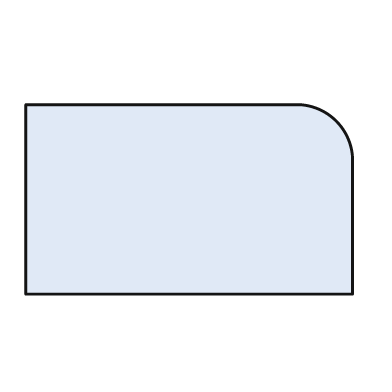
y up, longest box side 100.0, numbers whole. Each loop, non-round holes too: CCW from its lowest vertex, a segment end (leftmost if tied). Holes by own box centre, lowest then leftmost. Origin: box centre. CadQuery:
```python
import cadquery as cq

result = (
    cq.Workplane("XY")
    .moveTo(-50.0, -29.0)
    .lineTo(50.0, -29.0)
    .lineTo(50.0, 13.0)
    .threePointArc((45.0, 24.0), (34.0, 29.0))
    .lineTo(-50.0, 29.0)
    .close()
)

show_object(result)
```